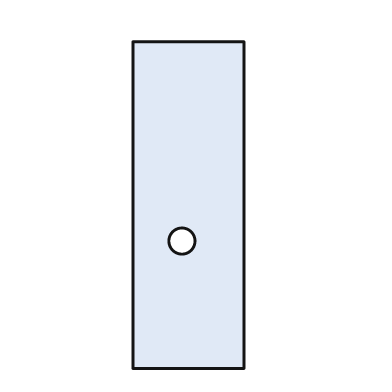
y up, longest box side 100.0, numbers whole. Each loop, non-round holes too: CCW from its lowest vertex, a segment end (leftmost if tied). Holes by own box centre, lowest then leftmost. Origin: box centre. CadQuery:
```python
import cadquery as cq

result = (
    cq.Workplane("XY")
    .moveTo(-17.0, -50.0)
    .lineTo(17.0, -50.0)
    .lineTo(17.0, 50.0)
    .lineTo(-17.0, 50.0)
    .close()
    .moveTo(-2.0, -11.0)
    .circle(4.0)
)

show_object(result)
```